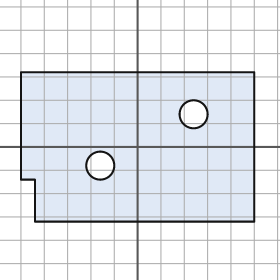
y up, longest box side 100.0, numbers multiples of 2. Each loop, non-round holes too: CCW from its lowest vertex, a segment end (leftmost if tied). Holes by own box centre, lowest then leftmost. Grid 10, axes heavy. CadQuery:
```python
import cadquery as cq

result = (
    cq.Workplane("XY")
    .moveTo(-44.0, -32.0)
    .lineTo(50.0, -32.0)
    .lineTo(50.0, 32.0)
    .lineTo(-50.0, 32.0)
    .lineTo(-50.0, -14.0)
    .lineTo(-44.0, -14.0)
    .close()
    .moveTo(-16.0, -8.0)
    .circle(6.0)
    .moveTo(24.0, 14.0)
    .circle(6.0)
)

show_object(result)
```